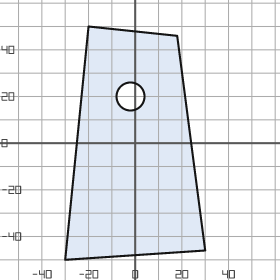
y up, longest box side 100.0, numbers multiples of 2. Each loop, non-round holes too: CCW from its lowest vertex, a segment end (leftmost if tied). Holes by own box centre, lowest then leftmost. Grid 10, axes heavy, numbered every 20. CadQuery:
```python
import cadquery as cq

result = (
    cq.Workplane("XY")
    .moveTo(-30.0, -50.0)
    .lineTo(30.0, -46.0)
    .lineTo(18.0, 46.0)
    .lineTo(-20.0, 50.0)
    .close()
    .moveTo(-2.0, 20.0)
    .circle(6.0)
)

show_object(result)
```